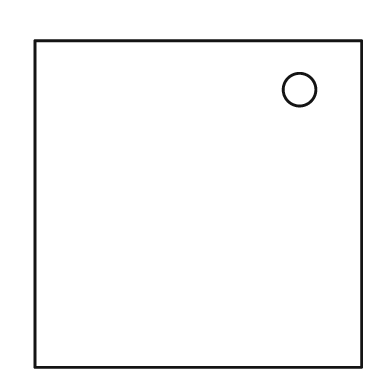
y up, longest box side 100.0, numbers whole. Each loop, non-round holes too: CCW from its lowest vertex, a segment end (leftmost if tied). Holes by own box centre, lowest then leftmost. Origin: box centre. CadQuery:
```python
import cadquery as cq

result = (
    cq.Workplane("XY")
    .moveTo(-50.0, -50.0)
    .lineTo(50.0, -50.0)
    .lineTo(50.0, 50.0)
    .lineTo(-50.0, 50.0)
    .close()
    .moveTo(31.0, 35.0)
    .circle(5.0)
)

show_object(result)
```